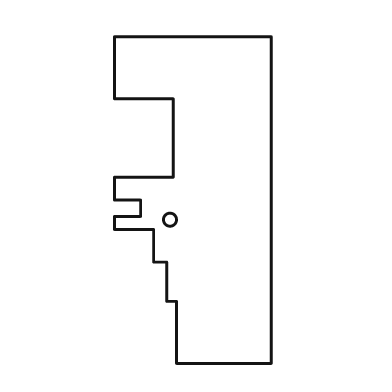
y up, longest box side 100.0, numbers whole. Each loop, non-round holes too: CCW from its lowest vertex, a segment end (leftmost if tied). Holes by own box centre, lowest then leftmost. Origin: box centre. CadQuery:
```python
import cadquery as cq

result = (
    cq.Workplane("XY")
    .moveTo(-5.0, -50.0)
    .lineTo(24.0, -50.0)
    .lineTo(24.0, 50.0)
    .lineTo(-24.0, 50.0)
    .lineTo(-24.0, 31.0)
    .lineTo(-6.0, 31.0)
    .lineTo(-6.0, 7.0)
    .lineTo(-24.0, 7.0)
    .lineTo(-24.0, 0.0)
    .lineTo(-16.0, 0.0)
    .lineTo(-16.0, -5.0)
    .lineTo(-24.0, -5.0)
    .lineTo(-24.0, -9.0)
    .lineTo(-12.0, -9.0)
    .lineTo(-12.0, -19.0)
    .lineTo(-8.0, -19.0)
    .lineTo(-8.0, -31.0)
    .lineTo(-5.0, -31.0)
    .close()
    .moveTo(-7.0, -6.0)
    .circle(2.0)
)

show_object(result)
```